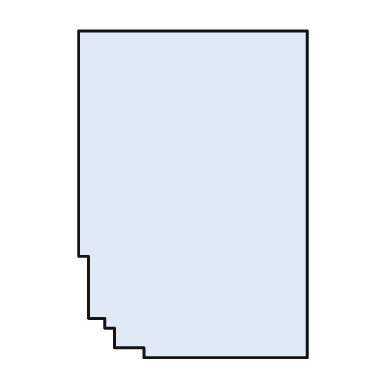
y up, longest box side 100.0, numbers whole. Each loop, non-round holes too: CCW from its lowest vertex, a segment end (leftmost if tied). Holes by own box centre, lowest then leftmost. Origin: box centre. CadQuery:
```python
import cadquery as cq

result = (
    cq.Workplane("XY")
    .moveTo(-15.0, -50.0)
    .lineTo(35.0, -50.0)
    .lineTo(35.0, 50.0)
    .lineTo(-35.0, 50.0)
    .lineTo(-35.0, -19.0)
    .lineTo(-32.0, -19.0)
    .lineTo(-32.0, -38.0)
    .lineTo(-27.0, -38.0)
    .lineTo(-27.0, -41.0)
    .lineTo(-24.0, -41.0)
    .lineTo(-24.0, -47.0)
    .lineTo(-15.0, -47.0)
    .close()
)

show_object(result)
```